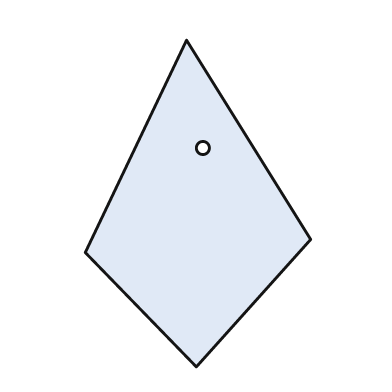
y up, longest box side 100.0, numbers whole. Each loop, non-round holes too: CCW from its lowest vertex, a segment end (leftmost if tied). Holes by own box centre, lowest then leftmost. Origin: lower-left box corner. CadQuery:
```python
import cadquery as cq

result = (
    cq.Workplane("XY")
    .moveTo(34.0, 0.0)
    .lineTo(69.0, 39.0)
    .lineTo(31.0, 100.0)
    .lineTo(0.0, 35.0)
    .close()
    .moveTo(36.0, 67.0)
    .circle(2.0)
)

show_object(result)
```